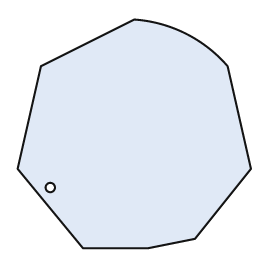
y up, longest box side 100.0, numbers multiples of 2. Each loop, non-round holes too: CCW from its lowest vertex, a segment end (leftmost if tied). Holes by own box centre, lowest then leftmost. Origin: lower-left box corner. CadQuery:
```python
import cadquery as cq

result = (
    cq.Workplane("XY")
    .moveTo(28.0, 0.0)
    .lineTo(56.0, 0.0)
    .lineTo(76.0, 4.0)
    .lineTo(100.0, 34.0)
    .lineTo(90.0, 78.0)
    .threePointArc((72.0, 92.0), (50.0, 98.0))
    .lineTo(10.0, 78.0)
    .lineTo(0.0, 34.0)
    .close()
    .moveTo(14.0, 26.0)
    .circle(2.0)
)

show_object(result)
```